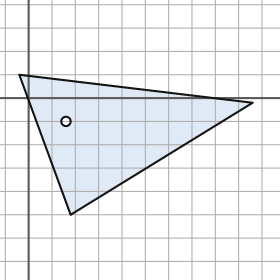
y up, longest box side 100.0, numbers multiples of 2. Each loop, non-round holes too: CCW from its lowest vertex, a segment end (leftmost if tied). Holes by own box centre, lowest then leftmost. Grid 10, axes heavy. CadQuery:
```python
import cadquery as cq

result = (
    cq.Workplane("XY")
    .moveTo(18.0, -50.0)
    .lineTo(96.0, -2.0)
    .lineTo(-4.0, 10.0)
    .close()
    .moveTo(16.0, -10.0)
    .circle(2.0)
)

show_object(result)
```